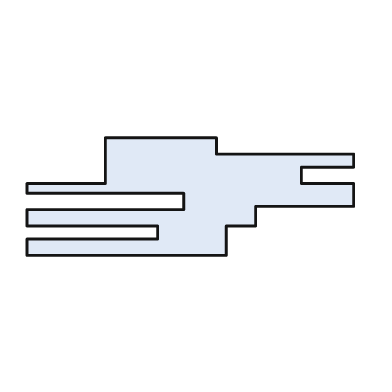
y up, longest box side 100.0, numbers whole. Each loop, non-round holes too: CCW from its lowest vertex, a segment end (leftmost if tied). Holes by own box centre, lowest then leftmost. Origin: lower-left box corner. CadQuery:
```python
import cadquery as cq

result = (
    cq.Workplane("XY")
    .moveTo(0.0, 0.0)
    .lineTo(61.0, 0.0)
    .lineTo(61.0, 9.0)
    .lineTo(70.0, 9.0)
    .lineTo(70.0, 15.0)
    .lineTo(100.0, 15.0)
    .lineTo(100.0, 22.0)
    .lineTo(84.0, 22.0)
    .lineTo(84.0, 27.0)
    .lineTo(100.0, 27.0)
    .lineTo(100.0, 31.0)
    .lineTo(58.0, 31.0)
    .lineTo(58.0, 36.0)
    .lineTo(24.0, 36.0)
    .lineTo(24.0, 22.0)
    .lineTo(0.0, 22.0)
    .lineTo(0.0, 19.0)
    .lineTo(48.0, 19.0)
    .lineTo(48.0, 14.0)
    .lineTo(0.0, 14.0)
    .lineTo(0.0, 9.0)
    .lineTo(40.0, 9.0)
    .lineTo(40.0, 5.0)
    .lineTo(0.0, 5.0)
    .close()
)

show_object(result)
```